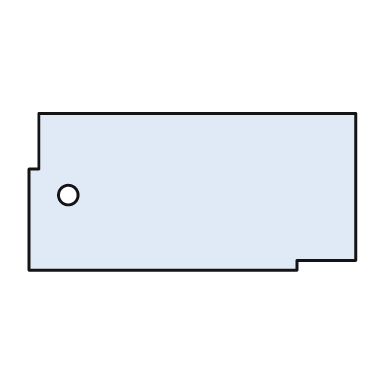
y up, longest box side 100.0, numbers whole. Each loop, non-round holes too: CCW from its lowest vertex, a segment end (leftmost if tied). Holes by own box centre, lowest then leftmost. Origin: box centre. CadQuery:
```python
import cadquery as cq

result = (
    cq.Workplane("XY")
    .moveTo(-50.0, -24.0)
    .lineTo(32.0, -24.0)
    .lineTo(32.0, -21.0)
    .lineTo(50.0, -21.0)
    .lineTo(50.0, 24.0)
    .lineTo(-47.0, 24.0)
    .lineTo(-47.0, 7.0)
    .lineTo(-50.0, 7.0)
    .close()
    .moveTo(-38.0, -1.0)
    .circle(3.0)
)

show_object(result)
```